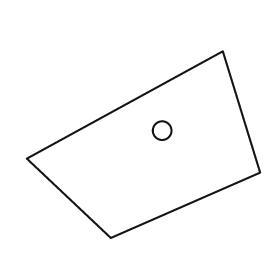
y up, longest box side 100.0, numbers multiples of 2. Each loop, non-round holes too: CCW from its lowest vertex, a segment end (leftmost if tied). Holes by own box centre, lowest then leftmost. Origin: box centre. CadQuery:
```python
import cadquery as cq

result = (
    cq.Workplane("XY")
    .moveTo(-14.0, -40.0)
    .lineTo(50.0, -12.0)
    .lineTo(34.0, 40.0)
    .lineTo(-50.0, -6.0)
    .close()
    .moveTo(8.0, 6.0)
    .circle(4.0)
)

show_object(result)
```